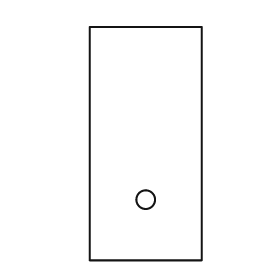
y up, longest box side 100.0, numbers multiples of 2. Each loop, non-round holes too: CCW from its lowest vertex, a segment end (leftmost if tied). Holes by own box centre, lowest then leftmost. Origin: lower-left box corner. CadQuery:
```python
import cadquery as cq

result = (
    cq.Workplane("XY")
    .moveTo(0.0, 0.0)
    .lineTo(48.0, 0.0)
    .lineTo(48.0, 100.0)
    .lineTo(0.0, 100.0)
    .close()
    .moveTo(24.0, 26.0)
    .circle(4.0)
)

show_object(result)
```